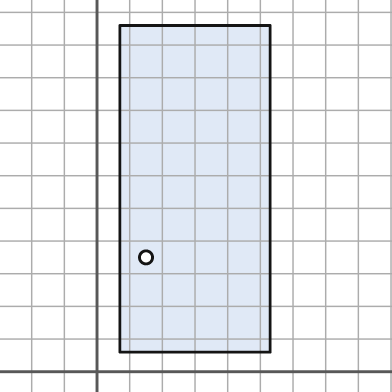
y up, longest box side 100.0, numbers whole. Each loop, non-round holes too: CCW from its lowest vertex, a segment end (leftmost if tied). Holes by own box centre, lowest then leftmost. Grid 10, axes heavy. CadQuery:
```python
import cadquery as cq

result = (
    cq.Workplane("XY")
    .moveTo(7.0, 6.0)
    .lineTo(53.0, 6.0)
    .lineTo(53.0, 106.0)
    .lineTo(7.0, 106.0)
    .close()
    .moveTo(15.0, 35.0)
    .circle(2.0)
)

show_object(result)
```